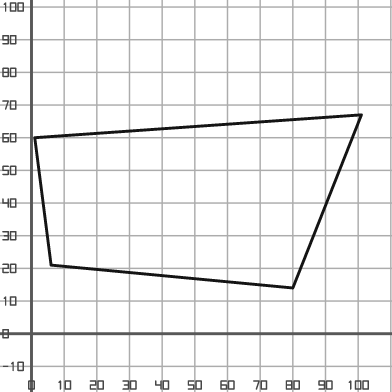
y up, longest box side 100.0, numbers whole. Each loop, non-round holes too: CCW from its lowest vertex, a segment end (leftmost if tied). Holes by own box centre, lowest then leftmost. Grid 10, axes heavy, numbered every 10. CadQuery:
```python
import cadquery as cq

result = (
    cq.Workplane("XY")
    .moveTo(80.0, 14.0)
    .lineTo(101.0, 67.0)
    .lineTo(1.0, 60.0)
    .lineTo(6.0, 21.0)
    .close()
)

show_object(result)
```